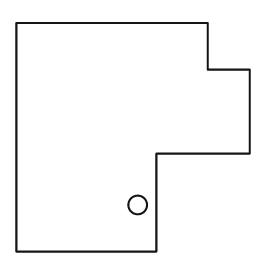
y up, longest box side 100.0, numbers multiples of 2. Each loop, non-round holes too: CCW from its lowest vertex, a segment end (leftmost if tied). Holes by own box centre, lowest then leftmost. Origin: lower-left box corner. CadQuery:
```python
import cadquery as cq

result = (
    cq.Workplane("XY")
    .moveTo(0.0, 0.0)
    .lineTo(60.0, 0.0)
    .lineTo(60.0, 42.0)
    .lineTo(100.0, 42.0)
    .lineTo(100.0, 78.0)
    .lineTo(82.0, 78.0)
    .lineTo(82.0, 98.0)
    .lineTo(0.0, 98.0)
    .close()
    .moveTo(52.0, 20.0)
    .circle(4.0)
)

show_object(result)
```